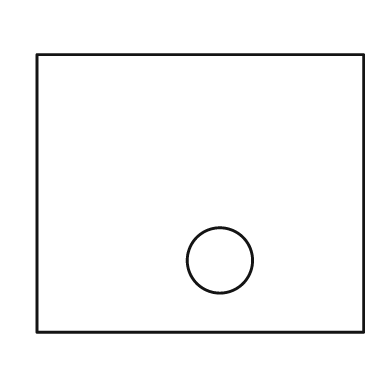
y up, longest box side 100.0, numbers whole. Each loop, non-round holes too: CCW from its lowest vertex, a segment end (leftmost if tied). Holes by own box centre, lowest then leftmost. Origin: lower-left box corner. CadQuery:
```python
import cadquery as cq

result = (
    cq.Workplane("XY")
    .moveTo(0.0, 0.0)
    .lineTo(100.0, 0.0)
    .lineTo(100.0, 85.0)
    .lineTo(0.0, 85.0)
    .close()
    .moveTo(56.0, 22.0)
    .circle(10.0)
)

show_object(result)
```